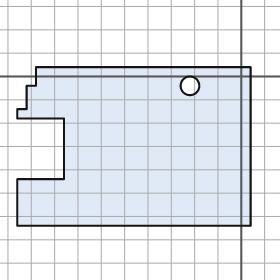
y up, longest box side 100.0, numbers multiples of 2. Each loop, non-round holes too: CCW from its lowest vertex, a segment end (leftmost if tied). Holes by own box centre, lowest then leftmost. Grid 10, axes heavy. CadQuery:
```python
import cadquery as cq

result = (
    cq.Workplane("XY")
    .moveTo(-96.0, -64.0)
    .lineTo(4.0, -64.0)
    .lineTo(4.0, 4.0)
    .lineTo(-88.0, 4.0)
    .lineTo(-88.0, -4.0)
    .lineTo(-92.0, -4.0)
    .lineTo(-92.0, -14.0)
    .lineTo(-96.0, -14.0)
    .lineTo(-96.0, -18.0)
    .lineTo(-76.0, -18.0)
    .lineTo(-76.0, -44.0)
    .lineTo(-96.0, -44.0)
    .close()
    .moveTo(-22.0, -4.0)
    .circle(4.0)
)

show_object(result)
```